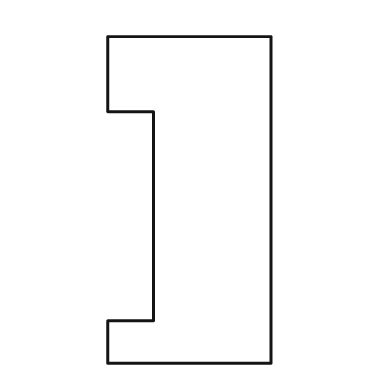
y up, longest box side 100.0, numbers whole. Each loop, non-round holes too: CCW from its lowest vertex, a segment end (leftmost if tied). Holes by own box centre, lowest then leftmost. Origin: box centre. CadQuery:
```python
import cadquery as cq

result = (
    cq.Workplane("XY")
    .moveTo(-25.0, -50.0)
    .lineTo(25.0, -50.0)
    .lineTo(25.0, 50.0)
    .lineTo(-25.0, 50.0)
    .lineTo(-25.0, 27.0)
    .lineTo(-11.0, 27.0)
    .lineTo(-11.0, -37.0)
    .lineTo(-25.0, -37.0)
    .close()
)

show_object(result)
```